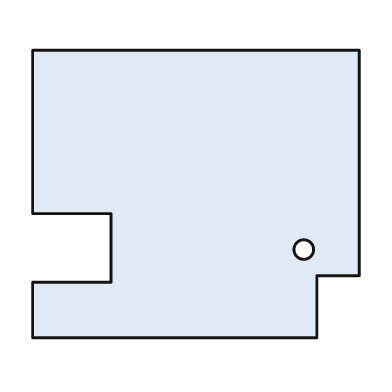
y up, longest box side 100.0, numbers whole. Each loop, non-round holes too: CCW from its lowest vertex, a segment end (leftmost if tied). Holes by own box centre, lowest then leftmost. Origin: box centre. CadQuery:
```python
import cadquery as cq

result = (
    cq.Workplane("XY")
    .moveTo(-50.0, -44.0)
    .lineTo(37.0, -44.0)
    .lineTo(37.0, -25.0)
    .lineTo(50.0, -25.0)
    .lineTo(50.0, 44.0)
    .lineTo(-50.0, 44.0)
    .lineTo(-50.0, -6.0)
    .lineTo(-26.0, -6.0)
    .lineTo(-26.0, -27.0)
    .lineTo(-50.0, -27.0)
    .close()
    .moveTo(33.0, -17.0)
    .circle(3.0)
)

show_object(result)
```